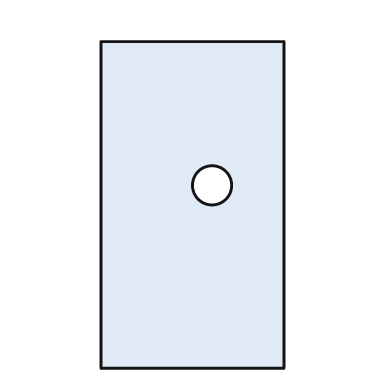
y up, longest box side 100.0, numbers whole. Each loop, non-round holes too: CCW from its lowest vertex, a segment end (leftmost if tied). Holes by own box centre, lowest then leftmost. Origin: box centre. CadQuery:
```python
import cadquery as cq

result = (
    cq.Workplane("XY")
    .moveTo(-28.0, -50.0)
    .lineTo(28.0, -50.0)
    .lineTo(28.0, 50.0)
    .lineTo(-28.0, 50.0)
    .close()
    .moveTo(6.0, 6.0)
    .circle(6.0)
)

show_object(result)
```